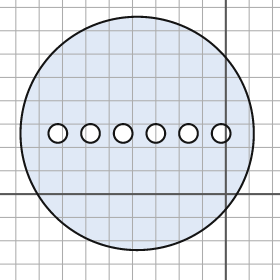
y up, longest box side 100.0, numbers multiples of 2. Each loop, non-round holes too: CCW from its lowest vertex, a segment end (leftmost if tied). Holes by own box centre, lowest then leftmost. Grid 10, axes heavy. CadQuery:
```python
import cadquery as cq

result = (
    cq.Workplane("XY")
    .moveTo(-38.0, 26.0)
    .circle(50.0)
    .moveTo(-72.0, 26.0)
    .circle(4.0)
    .moveTo(-58.0, 26.0)
    .circle(4.0)
    .moveTo(-44.0, 26.0)
    .circle(4.0)
    .moveTo(-30.0, 26.0)
    .circle(4.0)
    .moveTo(-16.0, 26.0)
    .circle(4.0)
    .moveTo(-2.0, 26.0)
    .circle(4.0)
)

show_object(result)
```